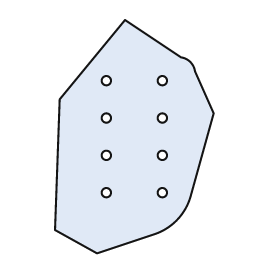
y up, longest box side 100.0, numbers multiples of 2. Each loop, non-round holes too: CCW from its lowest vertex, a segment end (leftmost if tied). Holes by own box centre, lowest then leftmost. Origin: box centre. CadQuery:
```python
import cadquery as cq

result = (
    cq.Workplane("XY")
    .moveTo(-16.0, -50.0)
    .lineTo(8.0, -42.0)
    .threePointArc((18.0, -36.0), (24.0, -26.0))
    .lineTo(34.0, 10.0)
    .lineTo(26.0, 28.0)
    .threePointArc((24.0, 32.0), (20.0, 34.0))
    .lineTo(-4.0, 50.0)
    .lineTo(-32.0, 16.0)
    .lineTo(-34.0, -40.0)
    .close()
    .moveTo(-12.0, -24.0)
    .circle(2.0)
    .moveTo(12.0, -24.0)
    .circle(2.0)
    .moveTo(-12.0, -8.0)
    .circle(2.0)
    .moveTo(12.0, -8.0)
    .circle(2.0)
    .moveTo(-12.0, 8.0)
    .circle(2.0)
    .moveTo(12.0, 8.0)
    .circle(2.0)
    .moveTo(-12.0, 24.0)
    .circle(2.0)
    .moveTo(12.0, 24.0)
    .circle(2.0)
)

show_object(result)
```